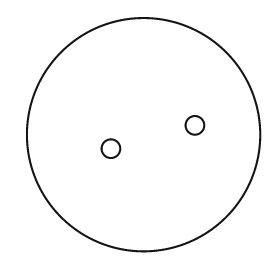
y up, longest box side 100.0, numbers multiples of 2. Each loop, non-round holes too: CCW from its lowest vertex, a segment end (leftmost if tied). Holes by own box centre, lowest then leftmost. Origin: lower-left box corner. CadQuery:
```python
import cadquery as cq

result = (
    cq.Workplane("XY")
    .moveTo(50.0, 50.0)
    .circle(50.0)
    .moveTo(36.0, 44.0)
    .circle(4.0)
    .moveTo(72.0, 54.0)
    .circle(4.0)
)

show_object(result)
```